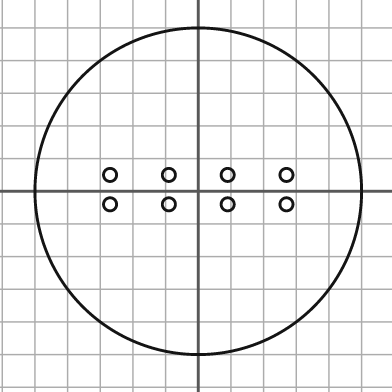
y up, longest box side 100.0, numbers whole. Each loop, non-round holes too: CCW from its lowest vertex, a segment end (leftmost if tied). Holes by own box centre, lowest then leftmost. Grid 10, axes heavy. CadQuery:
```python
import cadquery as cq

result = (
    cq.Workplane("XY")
    .moveTo(0.0, 0.0)
    .circle(50.0)
    .moveTo(-27.0, -4.0)
    .circle(2.0)
    .moveTo(-9.0, -4.0)
    .circle(2.0)
    .moveTo(9.0, -4.0)
    .circle(2.0)
    .moveTo(27.0, -4.0)
    .circle(2.0)
    .moveTo(-27.0, 5.0)
    .circle(2.0)
    .moveTo(-9.0, 5.0)
    .circle(2.0)
    .moveTo(9.0, 5.0)
    .circle(2.0)
    .moveTo(27.0, 5.0)
    .circle(2.0)
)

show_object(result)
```